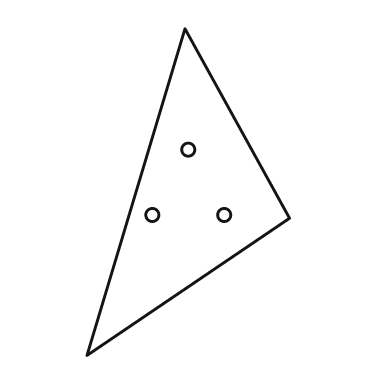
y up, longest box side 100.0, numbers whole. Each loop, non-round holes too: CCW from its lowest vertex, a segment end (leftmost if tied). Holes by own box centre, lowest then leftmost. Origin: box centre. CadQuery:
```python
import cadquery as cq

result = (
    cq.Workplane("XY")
    .moveTo(-31.0, -50.0)
    .lineTo(31.0, -8.0)
    .lineTo(-1.0, 50.0)
    .close()
    .moveTo(-11.0, -7.0)
    .circle(2.0)
    .moveTo(11.0, -7.0)
    .circle(2.0)
    .moveTo(0.0, 13.0)
    .circle(2.0)
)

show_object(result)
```